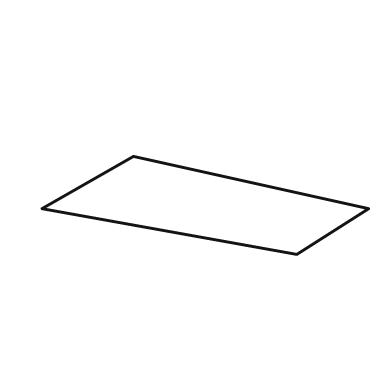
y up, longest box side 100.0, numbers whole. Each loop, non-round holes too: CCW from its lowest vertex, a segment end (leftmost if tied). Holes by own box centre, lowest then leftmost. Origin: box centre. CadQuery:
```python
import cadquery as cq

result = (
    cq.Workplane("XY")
    .moveTo(28.0, -15.0)
    .lineTo(50.0, -1.0)
    .lineTo(-22.0, 15.0)
    .lineTo(-50.0, -1.0)
    .close()
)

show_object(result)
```